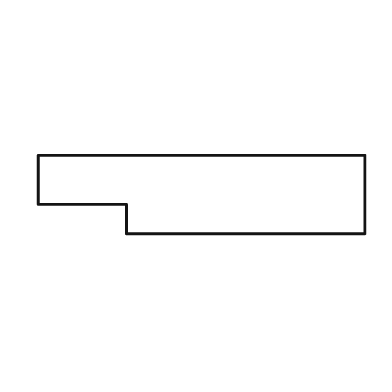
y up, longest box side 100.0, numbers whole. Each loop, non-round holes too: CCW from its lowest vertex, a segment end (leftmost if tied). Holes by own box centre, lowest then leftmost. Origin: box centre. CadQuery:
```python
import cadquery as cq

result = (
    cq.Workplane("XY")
    .moveTo(-23.0, -12.0)
    .lineTo(50.0, -12.0)
    .lineTo(50.0, 12.0)
    .lineTo(-50.0, 12.0)
    .lineTo(-50.0, -3.0)
    .lineTo(-23.0, -3.0)
    .close()
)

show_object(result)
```